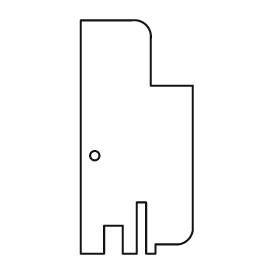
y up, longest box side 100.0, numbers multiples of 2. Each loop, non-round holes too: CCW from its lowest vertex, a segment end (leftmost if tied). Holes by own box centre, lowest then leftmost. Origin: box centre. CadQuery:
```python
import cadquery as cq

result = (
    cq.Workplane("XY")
    .moveTo(-24.0, -50.0)
    .lineTo(-14.0, -50.0)
    .lineTo(-14.0, -38.0)
    .lineTo(-6.0, -38.0)
    .lineTo(-6.0, -50.0)
    .lineTo(0.0, -50.0)
    .lineTo(0.0, -28.0)
    .lineTo(4.0, -28.0)
    .lineTo(4.0, -50.0)
    .lineTo(8.0, -50.0)
    .lineTo(8.0, -46.0)
    .lineTo(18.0, -46.0)
    .threePointArc((22.0, -44.0), (24.0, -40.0))
    .lineTo(24.0, 22.0)
    .lineTo(6.0, 22.0)
    .lineTo(6.0, 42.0)
    .threePointArc((4.0, 48.0), (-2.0, 50.0))
    .lineTo(-24.0, 50.0)
    .close()
    .moveTo(-18.0, -8.0)
    .circle(2.0)
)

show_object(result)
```